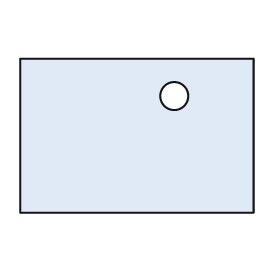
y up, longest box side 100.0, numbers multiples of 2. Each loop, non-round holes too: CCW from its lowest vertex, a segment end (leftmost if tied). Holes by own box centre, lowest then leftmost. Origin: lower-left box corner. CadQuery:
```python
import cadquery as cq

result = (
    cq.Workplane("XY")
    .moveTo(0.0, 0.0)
    .lineTo(100.0, 0.0)
    .lineTo(100.0, 66.0)
    .lineTo(0.0, 66.0)
    .close()
    .moveTo(66.0, 50.0)
    .circle(6.0)
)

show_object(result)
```